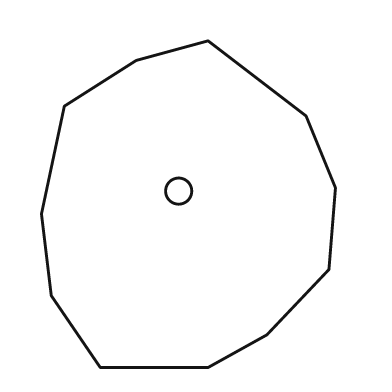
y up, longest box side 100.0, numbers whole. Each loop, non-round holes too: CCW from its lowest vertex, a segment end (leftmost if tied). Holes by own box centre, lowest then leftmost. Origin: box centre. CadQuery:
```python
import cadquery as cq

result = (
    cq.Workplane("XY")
    .moveTo(-27.0, -50.0)
    .lineTo(6.0, -50.0)
    .lineTo(24.0, -40.0)
    .lineTo(43.0, -20.0)
    .lineTo(45.0, 5.0)
    .lineTo(36.0, 27.0)
    .lineTo(6.0, 50.0)
    .lineTo(-16.0, 44.0)
    .lineTo(-38.0, 30.0)
    .lineTo(-45.0, -3.0)
    .lineTo(-42.0, -28.0)
    .close()
    .moveTo(-3.0, 4.0)
    .circle(4.0)
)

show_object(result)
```